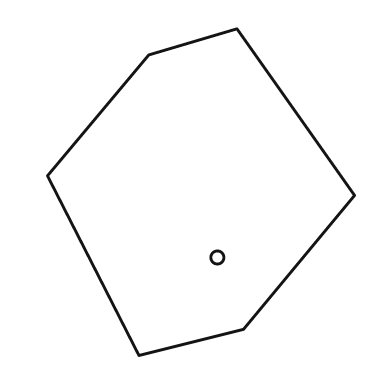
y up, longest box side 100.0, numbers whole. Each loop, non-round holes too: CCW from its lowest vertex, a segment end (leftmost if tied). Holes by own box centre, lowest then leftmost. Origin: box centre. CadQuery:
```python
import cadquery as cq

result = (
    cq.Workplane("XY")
    .moveTo(-19.0, -50.0)
    .lineTo(13.0, -42.0)
    .lineTo(47.0, -1.0)
    .lineTo(11.0, 50.0)
    .lineTo(-16.0, 42.0)
    .lineTo(-47.0, 5.0)
    .close()
    .moveTo(5.0, -20.0)
    .circle(2.0)
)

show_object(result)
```